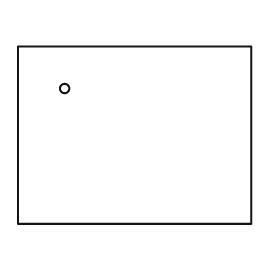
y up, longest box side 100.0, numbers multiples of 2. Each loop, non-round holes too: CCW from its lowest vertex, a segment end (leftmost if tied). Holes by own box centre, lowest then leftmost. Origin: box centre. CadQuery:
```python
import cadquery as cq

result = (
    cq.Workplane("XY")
    .moveTo(-50.0, -38.0)
    .lineTo(50.0, -38.0)
    .lineTo(50.0, 38.0)
    .lineTo(-50.0, 38.0)
    .close()
    .moveTo(-30.0, 20.0)
    .circle(2.0)
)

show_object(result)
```